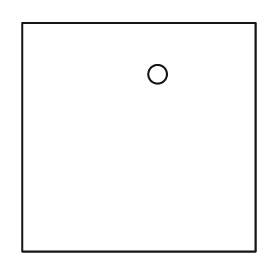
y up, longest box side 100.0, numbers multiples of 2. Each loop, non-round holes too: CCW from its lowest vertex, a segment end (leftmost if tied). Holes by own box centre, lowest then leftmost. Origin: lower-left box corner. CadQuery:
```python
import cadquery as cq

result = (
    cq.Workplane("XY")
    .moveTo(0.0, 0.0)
    .lineTo(100.0, 0.0)
    .lineTo(100.0, 98.0)
    .lineTo(0.0, 98.0)
    .close()
    .moveTo(58.0, 76.0)
    .circle(4.0)
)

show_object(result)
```